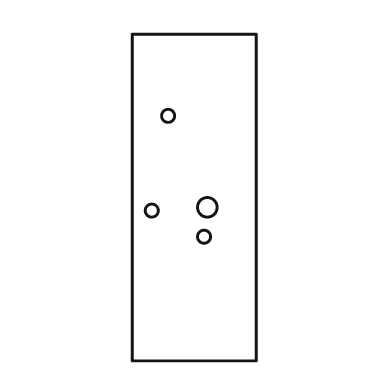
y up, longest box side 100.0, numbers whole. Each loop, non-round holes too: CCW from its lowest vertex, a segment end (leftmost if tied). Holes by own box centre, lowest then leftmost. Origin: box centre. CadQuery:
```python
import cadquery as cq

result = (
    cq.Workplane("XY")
    .moveTo(-19.0, -50.0)
    .lineTo(19.0, -50.0)
    .lineTo(19.0, 50.0)
    .lineTo(-19.0, 50.0)
    .close()
    .moveTo(3.0, -12.0)
    .circle(2.0)
    .moveTo(-13.0, -4.0)
    .circle(2.0)
    .moveTo(4.0, -3.0)
    .circle(3.0)
    .moveTo(-8.0, 25.0)
    .circle(2.0)
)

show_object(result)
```